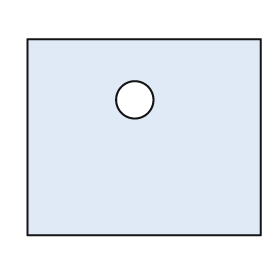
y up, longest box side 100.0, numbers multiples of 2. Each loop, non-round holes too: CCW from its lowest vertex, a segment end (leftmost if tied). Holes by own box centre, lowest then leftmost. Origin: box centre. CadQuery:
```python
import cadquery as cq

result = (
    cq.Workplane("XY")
    .moveTo(-50.0, -42.0)
    .lineTo(50.0, -42.0)
    .lineTo(50.0, 42.0)
    .lineTo(-50.0, 42.0)
    .close()
    .moveTo(-4.0, 16.0)
    .circle(8.0)
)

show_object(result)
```